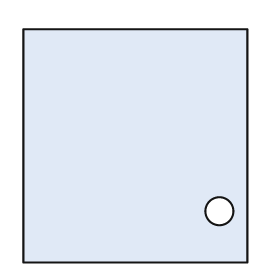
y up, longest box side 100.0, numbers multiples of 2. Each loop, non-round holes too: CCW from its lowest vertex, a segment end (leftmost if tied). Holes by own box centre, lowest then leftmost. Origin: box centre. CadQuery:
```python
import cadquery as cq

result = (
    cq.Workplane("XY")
    .moveTo(-48.0, -50.0)
    .lineTo(48.0, -50.0)
    .lineTo(48.0, 50.0)
    .lineTo(-48.0, 50.0)
    .close()
    .moveTo(36.0, -28.0)
    .circle(6.0)
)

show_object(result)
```